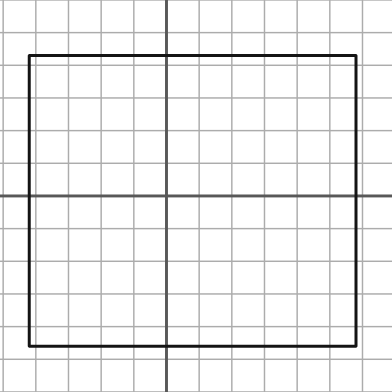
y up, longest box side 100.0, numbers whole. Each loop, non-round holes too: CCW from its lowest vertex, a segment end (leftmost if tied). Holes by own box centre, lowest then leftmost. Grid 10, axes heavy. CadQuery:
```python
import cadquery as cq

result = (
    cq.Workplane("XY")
    .moveTo(-42.0, -46.0)
    .lineTo(58.0, -46.0)
    .lineTo(58.0, 43.0)
    .lineTo(-42.0, 43.0)
    .close()
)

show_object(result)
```